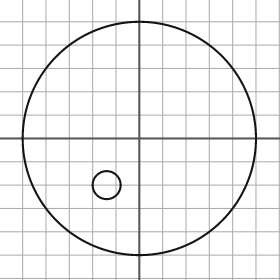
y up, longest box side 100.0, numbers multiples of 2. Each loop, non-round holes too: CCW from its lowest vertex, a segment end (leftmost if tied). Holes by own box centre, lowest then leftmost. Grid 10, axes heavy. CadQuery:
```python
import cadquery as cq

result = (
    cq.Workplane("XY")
    .moveTo(0.0, 0.0)
    .circle(50.0)
    .moveTo(-14.0, -20.0)
    .circle(6.0)
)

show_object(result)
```